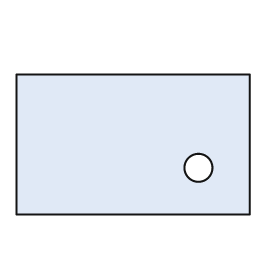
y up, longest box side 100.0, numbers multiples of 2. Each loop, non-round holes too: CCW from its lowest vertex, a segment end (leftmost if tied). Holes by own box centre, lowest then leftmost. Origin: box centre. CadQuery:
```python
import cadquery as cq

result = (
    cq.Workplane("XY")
    .moveTo(-50.0, -30.0)
    .lineTo(50.0, -30.0)
    .lineTo(50.0, 30.0)
    .lineTo(-50.0, 30.0)
    .close()
    .moveTo(28.0, -10.0)
    .circle(6.0)
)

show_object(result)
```